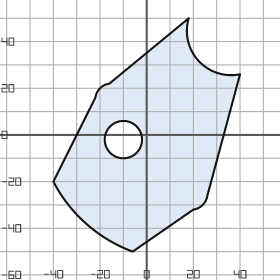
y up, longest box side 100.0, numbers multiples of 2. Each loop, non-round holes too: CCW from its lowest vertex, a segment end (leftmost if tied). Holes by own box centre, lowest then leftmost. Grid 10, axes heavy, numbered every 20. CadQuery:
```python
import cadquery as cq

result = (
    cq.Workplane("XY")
    .moveTo(-6.0, -50.0)
    .lineTo(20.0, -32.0)
    .threePointArc((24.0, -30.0), (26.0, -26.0))
    .lineTo(40.0, 26.0)
    .threePointArc((22.0, 32.0), (18.0, 50.0))
    .lineTo(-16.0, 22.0)
    .threePointArc((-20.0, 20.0), (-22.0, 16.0))
    .lineTo(-40.0, -20.0)
    .threePointArc((-26.0, -38.0), (-6.0, -50.0))
    .close()
    .moveTo(-10.0, -2.0)
    .circle(8.0)
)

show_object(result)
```